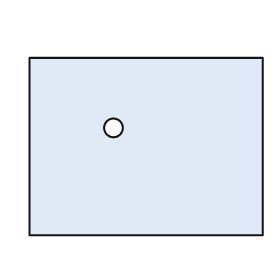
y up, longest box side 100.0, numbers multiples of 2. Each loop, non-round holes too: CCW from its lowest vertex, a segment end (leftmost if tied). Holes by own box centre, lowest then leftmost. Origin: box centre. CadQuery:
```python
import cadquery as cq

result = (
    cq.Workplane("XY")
    .moveTo(-50.0, -38.0)
    .lineTo(50.0, -38.0)
    .lineTo(50.0, 38.0)
    .lineTo(-50.0, 38.0)
    .close()
    .moveTo(-14.0, 8.0)
    .circle(4.0)
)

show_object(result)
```